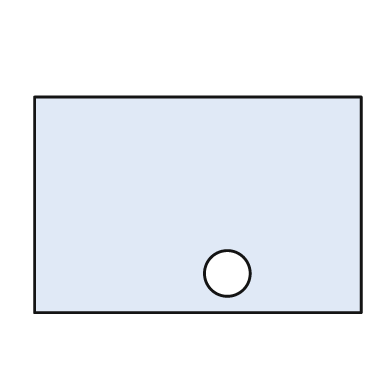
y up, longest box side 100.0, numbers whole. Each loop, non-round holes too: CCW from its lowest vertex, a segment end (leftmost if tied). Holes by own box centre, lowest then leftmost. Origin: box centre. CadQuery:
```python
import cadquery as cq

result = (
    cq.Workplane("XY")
    .moveTo(-50.0, -33.0)
    .lineTo(50.0, -33.0)
    .lineTo(50.0, 33.0)
    .lineTo(-50.0, 33.0)
    .close()
    .moveTo(9.0, -21.0)
    .circle(7.0)
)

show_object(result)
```